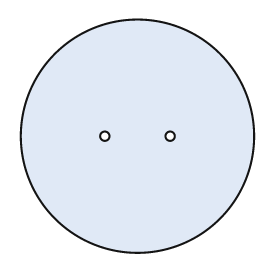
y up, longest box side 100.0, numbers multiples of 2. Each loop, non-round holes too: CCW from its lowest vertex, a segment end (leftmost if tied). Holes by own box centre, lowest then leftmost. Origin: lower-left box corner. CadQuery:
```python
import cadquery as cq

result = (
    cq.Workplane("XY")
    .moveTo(50.0, 50.0)
    .circle(50.0)
    .moveTo(36.0, 50.0)
    .circle(2.0)
    .moveTo(64.0, 50.0)
    .circle(2.0)
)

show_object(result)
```